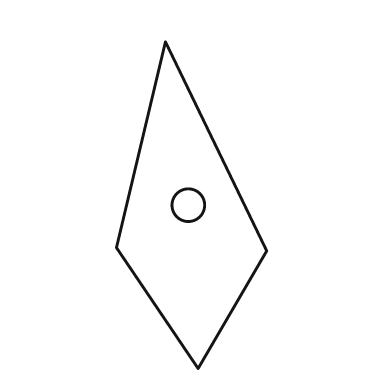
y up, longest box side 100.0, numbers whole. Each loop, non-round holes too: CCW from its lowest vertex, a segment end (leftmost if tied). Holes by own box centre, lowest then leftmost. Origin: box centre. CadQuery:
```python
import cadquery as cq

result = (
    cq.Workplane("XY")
    .moveTo(2.0, -50.0)
    .lineTo(23.0, -14.0)
    .lineTo(-8.0, 50.0)
    .lineTo(-23.0, -13.0)
    .close()
    .moveTo(-1.0, 0.0)
    .circle(5.0)
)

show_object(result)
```